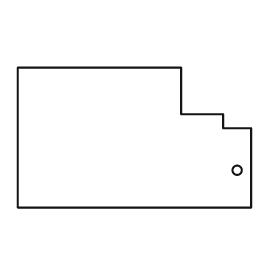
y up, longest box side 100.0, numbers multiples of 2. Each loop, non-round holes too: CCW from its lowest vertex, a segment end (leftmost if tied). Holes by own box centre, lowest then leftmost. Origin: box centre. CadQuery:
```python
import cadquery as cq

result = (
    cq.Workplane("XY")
    .moveTo(-50.0, -30.0)
    .lineTo(50.0, -30.0)
    .lineTo(50.0, 4.0)
    .lineTo(38.0, 4.0)
    .lineTo(38.0, 10.0)
    .lineTo(20.0, 10.0)
    .lineTo(20.0, 30.0)
    .lineTo(-50.0, 30.0)
    .close()
    .moveTo(44.0, -14.0)
    .circle(2.0)
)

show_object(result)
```